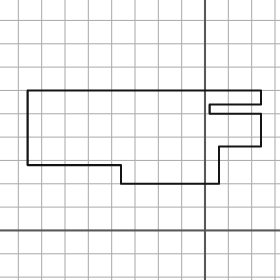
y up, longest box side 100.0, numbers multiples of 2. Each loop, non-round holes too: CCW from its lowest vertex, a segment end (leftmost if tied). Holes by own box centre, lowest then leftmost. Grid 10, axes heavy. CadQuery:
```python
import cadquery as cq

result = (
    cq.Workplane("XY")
    .moveTo(-36.0, 20.0)
    .lineTo(6.0, 20.0)
    .lineTo(6.0, 36.0)
    .lineTo(24.0, 36.0)
    .lineTo(24.0, 50.0)
    .lineTo(2.0, 50.0)
    .lineTo(2.0, 54.0)
    .lineTo(24.0, 54.0)
    .lineTo(24.0, 60.0)
    .lineTo(-76.0, 60.0)
    .lineTo(-76.0, 28.0)
    .lineTo(-36.0, 28.0)
    .close()
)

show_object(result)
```